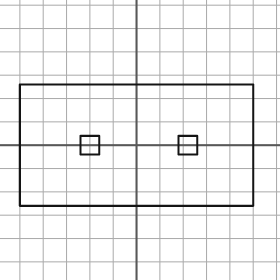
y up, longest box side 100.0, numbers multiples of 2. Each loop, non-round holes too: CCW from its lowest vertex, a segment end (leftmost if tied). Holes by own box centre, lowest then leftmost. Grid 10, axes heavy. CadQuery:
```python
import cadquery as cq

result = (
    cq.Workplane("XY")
    .moveTo(-50.0, -26.0)
    .lineTo(50.0, -26.0)
    .lineTo(50.0, 26.0)
    .lineTo(-50.0, 26.0)
    .close()
    .moveTo(-24.0, -4.0)
    .lineTo(-16.0, -4.0)
    .lineTo(-16.0, 4.0)
    .lineTo(-24.0, 4.0)
    .close()
    .moveTo(18.0, -4.0)
    .lineTo(26.0, -4.0)
    .lineTo(26.0, 4.0)
    .lineTo(18.0, 4.0)
    .close()
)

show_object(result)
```